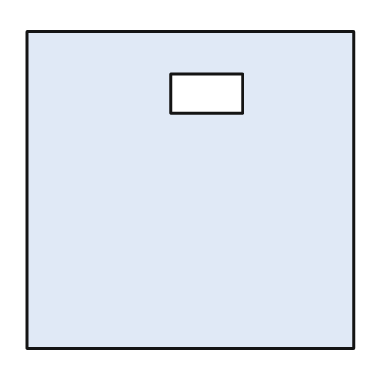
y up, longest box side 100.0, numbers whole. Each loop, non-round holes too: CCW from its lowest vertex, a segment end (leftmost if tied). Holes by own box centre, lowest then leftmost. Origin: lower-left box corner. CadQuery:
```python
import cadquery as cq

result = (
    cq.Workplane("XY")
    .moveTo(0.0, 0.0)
    .lineTo(100.0, 0.0)
    .lineTo(100.0, 97.0)
    .lineTo(0.0, 97.0)
    .close()
    .moveTo(44.0, 72.0)
    .lineTo(66.0, 72.0)
    .lineTo(66.0, 84.0)
    .lineTo(44.0, 84.0)
    .close()
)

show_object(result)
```